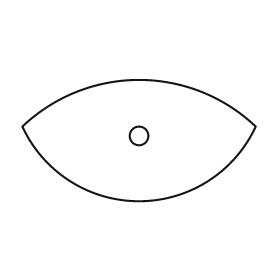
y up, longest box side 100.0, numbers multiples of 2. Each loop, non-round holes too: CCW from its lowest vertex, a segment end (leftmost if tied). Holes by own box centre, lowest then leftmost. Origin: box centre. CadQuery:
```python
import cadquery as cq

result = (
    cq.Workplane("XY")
    .moveTo(-50.0, 6.0)
    .threePointArc((0.0, -26.0), (50.0, 6.0))
    .threePointArc((0.0, 26.0), (-50.0, 6.0))
    .close()
    .moveTo(0.0, 2.0)
    .circle(4.0)
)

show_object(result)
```